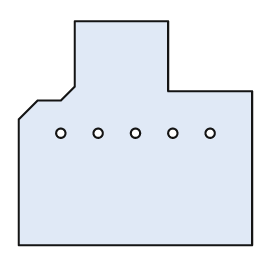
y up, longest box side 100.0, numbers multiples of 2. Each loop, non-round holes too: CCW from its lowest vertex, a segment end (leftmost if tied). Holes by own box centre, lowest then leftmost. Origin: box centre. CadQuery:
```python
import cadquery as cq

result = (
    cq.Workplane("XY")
    .moveTo(-50.0, -48.0)
    .lineTo(50.0, -48.0)
    .lineTo(50.0, 18.0)
    .lineTo(14.0, 18.0)
    .lineTo(14.0, 48.0)
    .lineTo(-26.0, 48.0)
    .lineTo(-26.0, 20.0)
    .lineTo(-32.0, 14.0)
    .lineTo(-42.0, 14.0)
    .lineTo(-50.0, 6.0)
    .close()
    .moveTo(-32.0, 0.0)
    .circle(2.0)
    .moveTo(-16.0, 0.0)
    .circle(2.0)
    .moveTo(0.0, 0.0)
    .circle(2.0)
    .moveTo(16.0, 0.0)
    .circle(2.0)
    .moveTo(32.0, 0.0)
    .circle(2.0)
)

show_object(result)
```